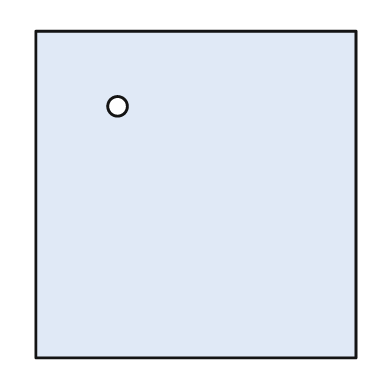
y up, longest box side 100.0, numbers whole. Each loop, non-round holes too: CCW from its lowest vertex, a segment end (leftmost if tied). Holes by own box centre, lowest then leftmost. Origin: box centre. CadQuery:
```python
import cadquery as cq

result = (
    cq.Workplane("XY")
    .moveTo(-49.0, -50.0)
    .lineTo(49.0, -50.0)
    .lineTo(49.0, 50.0)
    .lineTo(-49.0, 50.0)
    .close()
    .moveTo(-24.0, 27.0)
    .circle(3.0)
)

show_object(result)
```